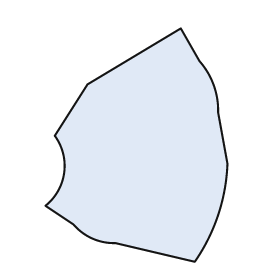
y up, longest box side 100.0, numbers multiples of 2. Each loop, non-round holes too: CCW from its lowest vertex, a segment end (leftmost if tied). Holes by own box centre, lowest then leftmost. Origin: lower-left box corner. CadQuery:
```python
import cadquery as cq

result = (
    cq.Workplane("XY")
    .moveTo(64.0, 0.0)
    .threePointArc((74.0, 20.0), (78.0, 42.0))
    .lineTo(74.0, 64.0)
    .threePointArc((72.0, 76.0), (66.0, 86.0))
    .lineTo(58.0, 100.0)
    .lineTo(18.0, 76.0)
    .lineTo(4.0, 54.0)
    .threePointArc((8.0, 38.0), (0.0, 24.0))
    .lineTo(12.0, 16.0)
    .threePointArc((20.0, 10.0), (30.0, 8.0))
    .close()
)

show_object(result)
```